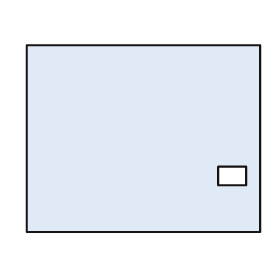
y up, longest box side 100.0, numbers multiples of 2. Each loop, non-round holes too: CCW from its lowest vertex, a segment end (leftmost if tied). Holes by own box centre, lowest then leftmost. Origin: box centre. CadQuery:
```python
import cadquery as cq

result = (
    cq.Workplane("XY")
    .moveTo(-50.0, -40.0)
    .lineTo(50.0, -40.0)
    .lineTo(50.0, 40.0)
    .lineTo(-50.0, 40.0)
    .close()
    .moveTo(32.0, -20.0)
    .lineTo(44.0, -20.0)
    .lineTo(44.0, -12.0)
    .lineTo(32.0, -12.0)
    .close()
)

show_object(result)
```